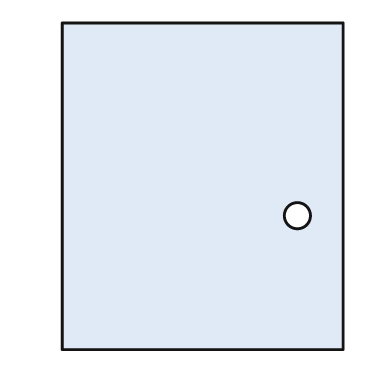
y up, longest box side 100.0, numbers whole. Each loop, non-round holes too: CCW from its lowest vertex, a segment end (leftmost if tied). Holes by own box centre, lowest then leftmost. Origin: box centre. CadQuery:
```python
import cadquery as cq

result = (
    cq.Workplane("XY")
    .moveTo(-43.0, -50.0)
    .lineTo(43.0, -50.0)
    .lineTo(43.0, 50.0)
    .lineTo(-43.0, 50.0)
    .close()
    .moveTo(29.0, -9.0)
    .circle(4.0)
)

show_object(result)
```